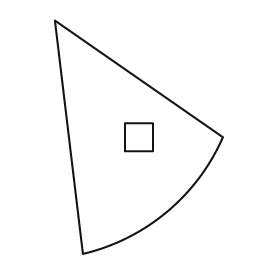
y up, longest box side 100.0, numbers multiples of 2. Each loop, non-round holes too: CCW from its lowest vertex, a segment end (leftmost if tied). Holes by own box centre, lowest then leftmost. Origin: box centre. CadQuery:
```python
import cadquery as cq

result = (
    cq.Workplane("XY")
    .moveTo(-24.0, -50.0)
    .threePointArc((12.0, -32.0), (36.0, 0.0))
    .lineTo(-36.0, 50.0)
    .close()
    .moveTo(-6.0, -6.0)
    .lineTo(6.0, -6.0)
    .lineTo(6.0, 6.0)
    .lineTo(-6.0, 6.0)
    .close()
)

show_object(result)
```